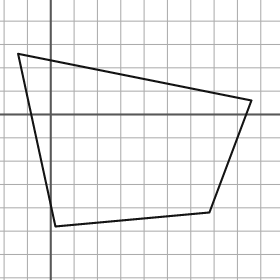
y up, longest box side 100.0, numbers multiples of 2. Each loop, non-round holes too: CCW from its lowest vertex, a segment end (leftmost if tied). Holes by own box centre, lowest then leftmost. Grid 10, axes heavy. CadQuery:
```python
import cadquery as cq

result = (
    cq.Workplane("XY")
    .moveTo(2.0, -48.0)
    .lineTo(68.0, -42.0)
    .lineTo(86.0, 6.0)
    .lineTo(-14.0, 26.0)
    .close()
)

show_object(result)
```